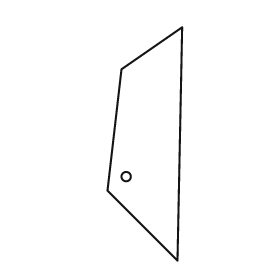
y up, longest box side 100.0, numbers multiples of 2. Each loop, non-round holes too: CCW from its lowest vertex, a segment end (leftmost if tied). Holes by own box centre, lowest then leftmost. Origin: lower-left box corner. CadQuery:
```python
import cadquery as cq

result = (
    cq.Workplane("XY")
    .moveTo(30.0, 0.0)
    .lineTo(32.0, 100.0)
    .lineTo(6.0, 82.0)
    .lineTo(0.0, 30.0)
    .close()
    .moveTo(8.0, 36.0)
    .circle(2.0)
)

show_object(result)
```